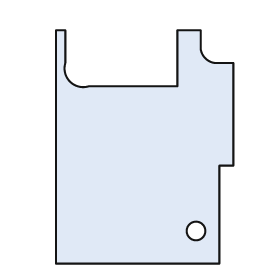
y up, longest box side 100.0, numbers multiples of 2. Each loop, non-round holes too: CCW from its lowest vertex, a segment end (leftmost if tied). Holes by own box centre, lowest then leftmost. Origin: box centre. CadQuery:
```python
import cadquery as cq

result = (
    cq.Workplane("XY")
    .moveTo(-38.0, -50.0)
    .lineTo(32.0, -50.0)
    .lineTo(32.0, -8.0)
    .lineTo(38.0, -8.0)
    .lineTo(38.0, 36.0)
    .lineTo(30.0, 36.0)
    .threePointArc((26.0, 38.0), (24.0, 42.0))
    .lineTo(24.0, 50.0)
    .lineTo(14.0, 50.0)
    .lineTo(14.0, 26.0)
    .lineTo(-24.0, 26.0)
    .threePointArc((-32.0, 28.0), (-34.0, 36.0))
    .lineTo(-34.0, 50.0)
    .lineTo(-38.0, 50.0)
    .close()
    .moveTo(22.0, -36.0)
    .circle(4.0)
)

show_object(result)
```